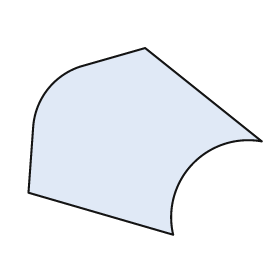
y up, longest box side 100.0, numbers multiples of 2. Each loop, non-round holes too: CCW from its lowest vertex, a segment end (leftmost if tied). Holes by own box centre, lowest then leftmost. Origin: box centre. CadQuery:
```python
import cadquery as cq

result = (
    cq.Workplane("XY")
    .moveTo(12.0, -40.0)
    .threePointArc((20.0, -10.0), (50.0, 0.0))
    .lineTo(0.0, 40.0)
    .lineTo(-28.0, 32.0)
    .threePointArc((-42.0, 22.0), (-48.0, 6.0))
    .lineTo(-50.0, -22.0)
    .close()
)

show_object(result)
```